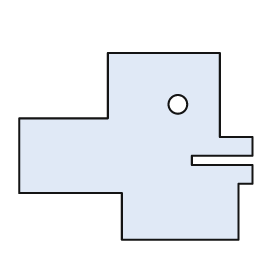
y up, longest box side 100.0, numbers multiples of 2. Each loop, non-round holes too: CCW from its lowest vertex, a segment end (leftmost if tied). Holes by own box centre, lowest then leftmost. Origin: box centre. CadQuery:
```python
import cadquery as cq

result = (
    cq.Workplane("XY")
    .moveTo(-6.0, -40.0)
    .lineTo(44.0, -40.0)
    .lineTo(44.0, -16.0)
    .lineTo(50.0, -16.0)
    .lineTo(50.0, -8.0)
    .lineTo(24.0, -8.0)
    .lineTo(24.0, -4.0)
    .lineTo(50.0, -4.0)
    .lineTo(50.0, 4.0)
    .lineTo(36.0, 4.0)
    .lineTo(36.0, 40.0)
    .lineTo(-12.0, 40.0)
    .lineTo(-12.0, 12.0)
    .lineTo(-50.0, 12.0)
    .lineTo(-50.0, -20.0)
    .lineTo(-6.0, -20.0)
    .close()
    .moveTo(18.0, 18.0)
    .circle(4.0)
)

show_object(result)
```